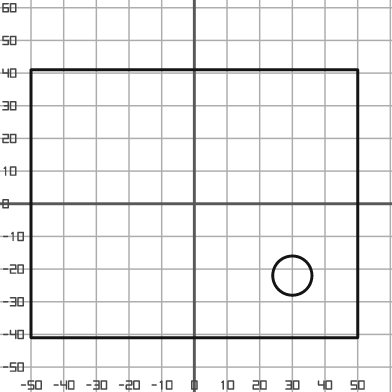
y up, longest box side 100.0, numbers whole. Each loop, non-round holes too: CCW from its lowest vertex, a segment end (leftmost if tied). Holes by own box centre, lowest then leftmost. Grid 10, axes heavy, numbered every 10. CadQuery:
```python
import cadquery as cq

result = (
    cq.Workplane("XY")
    .moveTo(-50.0, -41.0)
    .lineTo(50.0, -41.0)
    .lineTo(50.0, 41.0)
    .lineTo(-50.0, 41.0)
    .close()
    .moveTo(30.0, -22.0)
    .circle(6.0)
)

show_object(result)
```